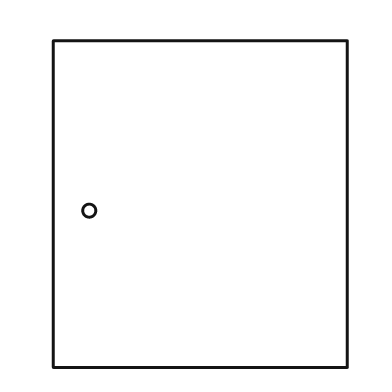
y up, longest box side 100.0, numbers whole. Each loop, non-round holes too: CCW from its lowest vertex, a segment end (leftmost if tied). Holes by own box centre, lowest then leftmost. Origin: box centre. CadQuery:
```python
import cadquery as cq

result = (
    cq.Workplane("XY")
    .moveTo(-45.0, -50.0)
    .lineTo(45.0, -50.0)
    .lineTo(45.0, 50.0)
    .lineTo(-45.0, 50.0)
    .close()
    .moveTo(-34.0, -2.0)
    .circle(2.0)
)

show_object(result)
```